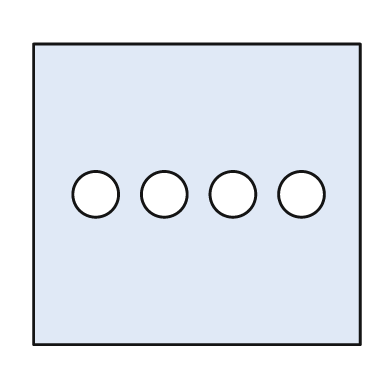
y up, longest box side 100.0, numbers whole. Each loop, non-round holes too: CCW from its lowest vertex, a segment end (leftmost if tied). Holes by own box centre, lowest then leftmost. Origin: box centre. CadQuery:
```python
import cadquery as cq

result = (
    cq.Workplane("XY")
    .moveTo(-50.0, -46.0)
    .lineTo(50.0, -46.0)
    .lineTo(50.0, 46.0)
    .lineTo(-50.0, 46.0)
    .close()
    .moveTo(-31.0, 0.0)
    .circle(7.0)
    .moveTo(-10.0, 0.0)
    .circle(7.0)
    .moveTo(11.0, 0.0)
    .circle(7.0)
    .moveTo(32.0, 0.0)
    .circle(7.0)
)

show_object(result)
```